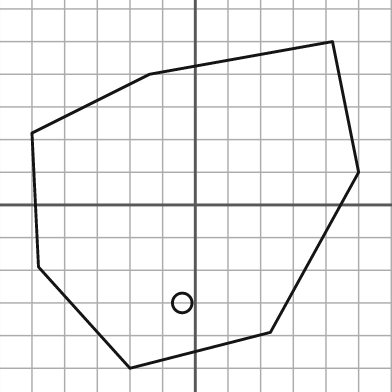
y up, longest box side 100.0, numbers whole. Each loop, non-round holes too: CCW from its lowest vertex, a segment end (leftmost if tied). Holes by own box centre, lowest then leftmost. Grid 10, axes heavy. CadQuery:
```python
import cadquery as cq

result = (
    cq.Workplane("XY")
    .moveTo(-20.0, -50.0)
    .lineTo(23.0, -39.0)
    .lineTo(50.0, 10.0)
    .lineTo(42.0, 50.0)
    .lineTo(-14.0, 40.0)
    .lineTo(-50.0, 22.0)
    .lineTo(-48.0, -19.0)
    .close()
    .moveTo(-4.0, -30.0)
    .circle(3.0)
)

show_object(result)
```